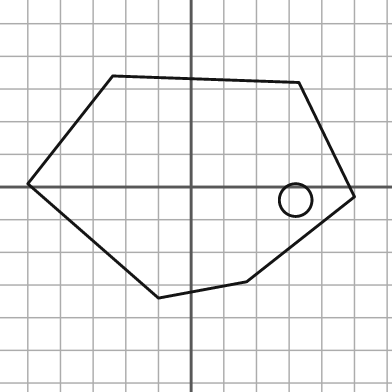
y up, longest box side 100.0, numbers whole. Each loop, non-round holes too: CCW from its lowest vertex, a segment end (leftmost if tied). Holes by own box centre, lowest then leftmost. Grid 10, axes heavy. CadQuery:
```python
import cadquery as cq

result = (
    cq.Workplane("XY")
    .moveTo(-10.0, -34.0)
    .lineTo(17.0, -29.0)
    .lineTo(50.0, -3.0)
    .lineTo(33.0, 32.0)
    .lineTo(-24.0, 34.0)
    .lineTo(-50.0, 1.0)
    .close()
    .moveTo(32.0, -4.0)
    .circle(5.0)
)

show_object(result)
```